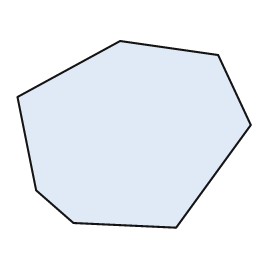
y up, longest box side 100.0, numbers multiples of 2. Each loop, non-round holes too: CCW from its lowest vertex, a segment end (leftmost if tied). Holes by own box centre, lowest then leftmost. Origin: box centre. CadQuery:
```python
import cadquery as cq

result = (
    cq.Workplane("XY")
    .moveTo(18.0, -40.0)
    .lineTo(50.0, 4.0)
    .lineTo(36.0, 34.0)
    .lineTo(-6.0, 40.0)
    .lineTo(-50.0, 16.0)
    .lineTo(-42.0, -24.0)
    .lineTo(-26.0, -38.0)
    .close()
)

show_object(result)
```